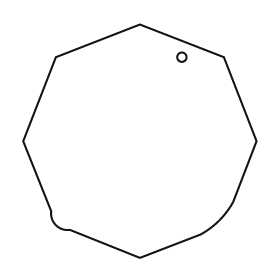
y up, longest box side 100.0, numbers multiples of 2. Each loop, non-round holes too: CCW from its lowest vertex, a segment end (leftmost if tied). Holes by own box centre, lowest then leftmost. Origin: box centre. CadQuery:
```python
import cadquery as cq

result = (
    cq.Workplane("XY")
    .moveTo(0.0, -50.0)
    .lineTo(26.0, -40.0)
    .threePointArc((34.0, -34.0), (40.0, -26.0))
    .lineTo(50.0, 0.0)
    .lineTo(36.0, 36.0)
    .lineTo(0.0, 50.0)
    .lineTo(-36.0, 36.0)
    .lineTo(-50.0, 0.0)
    .lineTo(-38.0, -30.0)
    .threePointArc((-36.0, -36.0), (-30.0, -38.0))
    .close()
    .moveTo(18.0, 36.0)
    .circle(2.0)
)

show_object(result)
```